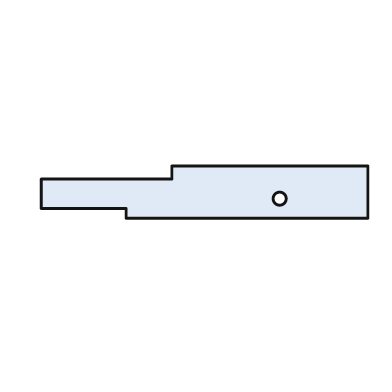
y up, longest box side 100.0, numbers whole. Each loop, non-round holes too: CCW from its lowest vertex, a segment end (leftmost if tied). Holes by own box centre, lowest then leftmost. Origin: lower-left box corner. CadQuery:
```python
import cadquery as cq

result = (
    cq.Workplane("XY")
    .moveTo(26.0, 0.0)
    .lineTo(100.0, 0.0)
    .lineTo(100.0, 16.0)
    .lineTo(40.0, 16.0)
    .lineTo(40.0, 12.0)
    .lineTo(0.0, 12.0)
    .lineTo(0.0, 3.0)
    .lineTo(26.0, 3.0)
    .close()
    .moveTo(73.0, 6.0)
    .circle(2.0)
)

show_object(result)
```